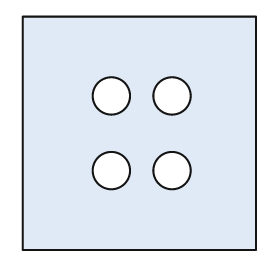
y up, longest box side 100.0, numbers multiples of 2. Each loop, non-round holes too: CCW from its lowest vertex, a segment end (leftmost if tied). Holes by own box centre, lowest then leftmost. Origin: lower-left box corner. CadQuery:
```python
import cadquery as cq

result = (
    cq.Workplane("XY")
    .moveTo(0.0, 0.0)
    .lineTo(100.0, 0.0)
    .lineTo(100.0, 100.0)
    .lineTo(0.0, 100.0)
    .close()
    .moveTo(38.0, 34.0)
    .circle(8.0)
    .moveTo(64.0, 34.0)
    .circle(8.0)
    .moveTo(38.0, 66.0)
    .circle(8.0)
    .moveTo(64.0, 66.0)
    .circle(8.0)
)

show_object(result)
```